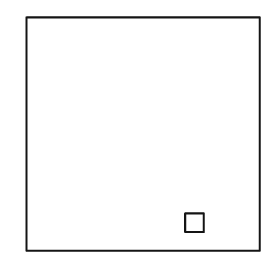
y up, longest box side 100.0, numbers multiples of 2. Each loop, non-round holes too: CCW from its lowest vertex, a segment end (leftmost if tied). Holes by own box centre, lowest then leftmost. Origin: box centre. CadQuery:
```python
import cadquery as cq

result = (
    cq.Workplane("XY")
    .moveTo(-50.0, -50.0)
    .lineTo(50.0, -50.0)
    .lineTo(50.0, 50.0)
    .lineTo(-50.0, 50.0)
    .close()
    .moveTo(18.0, -42.0)
    .lineTo(26.0, -42.0)
    .lineTo(26.0, -34.0)
    .lineTo(18.0, -34.0)
    .close()
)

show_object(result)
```